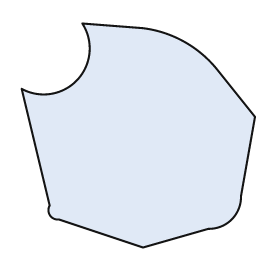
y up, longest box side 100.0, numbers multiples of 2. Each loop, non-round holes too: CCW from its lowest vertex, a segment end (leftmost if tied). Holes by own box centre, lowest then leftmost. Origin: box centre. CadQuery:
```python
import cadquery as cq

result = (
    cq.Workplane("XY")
    .moveTo(2.0, -48.0)
    .lineTo(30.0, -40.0)
    .threePointArc((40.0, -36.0), (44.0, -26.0))
    .lineTo(50.0, 8.0)
    .lineTo(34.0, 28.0)
    .threePointArc((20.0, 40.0), (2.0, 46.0))
    .lineTo(-24.0, 48.0)
    .threePointArc((-26.0, 24.0), (-50.0, 20.0))
    .lineTo(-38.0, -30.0)
    .threePointArc((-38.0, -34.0), (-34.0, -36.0))
    .close()
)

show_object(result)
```